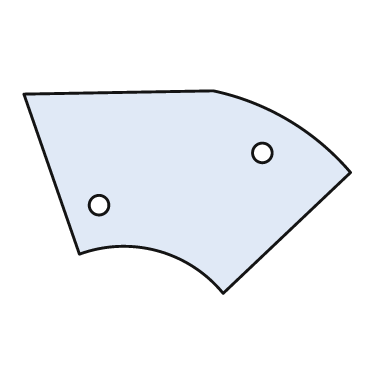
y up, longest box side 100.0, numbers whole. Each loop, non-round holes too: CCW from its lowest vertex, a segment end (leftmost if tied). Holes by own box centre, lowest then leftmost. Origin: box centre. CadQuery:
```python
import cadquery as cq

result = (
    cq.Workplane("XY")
    .moveTo(11.0, -31.0)
    .lineTo(50.0, 6.0)
    .threePointArc((31.0, 22.0), (8.0, 31.0))
    .lineTo(-50.0, 30.0)
    .lineTo(-33.0, -19.0)
    .threePointArc((-9.0, -18.0), (11.0, -31.0))
    .close()
    .moveTo(-27.0, -4.0)
    .circle(3.0)
    .moveTo(23.0, 12.0)
    .circle(3.0)
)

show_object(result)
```